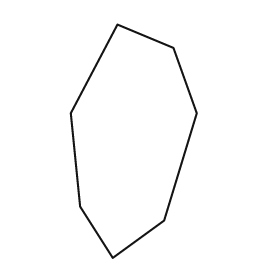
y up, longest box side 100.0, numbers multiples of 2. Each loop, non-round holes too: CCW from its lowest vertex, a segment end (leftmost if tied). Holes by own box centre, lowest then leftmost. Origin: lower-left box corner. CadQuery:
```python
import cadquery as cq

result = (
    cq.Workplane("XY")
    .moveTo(18.0, 0.0)
    .lineTo(40.0, 16.0)
    .lineTo(54.0, 62.0)
    .lineTo(44.0, 90.0)
    .lineTo(20.0, 100.0)
    .lineTo(0.0, 62.0)
    .lineTo(4.0, 22.0)
    .close()
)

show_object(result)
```